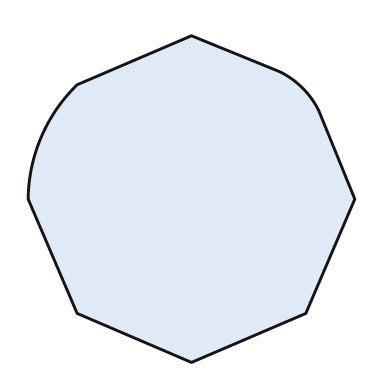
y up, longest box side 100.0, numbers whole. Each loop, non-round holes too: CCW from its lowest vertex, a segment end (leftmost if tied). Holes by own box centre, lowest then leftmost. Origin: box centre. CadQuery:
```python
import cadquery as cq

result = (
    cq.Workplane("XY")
    .moveTo(0.0, -50.0)
    .lineTo(35.0, -35.0)
    .lineTo(50.0, 0.0)
    .lineTo(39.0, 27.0)
    .threePointArc((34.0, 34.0), (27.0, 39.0))
    .lineTo(0.0, 50.0)
    .lineTo(-35.0, 35.0)
    .threePointArc((-46.0, 19.0), (-50.0, 0.0))
    .lineTo(-35.0, -35.0)
    .close()
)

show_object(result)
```